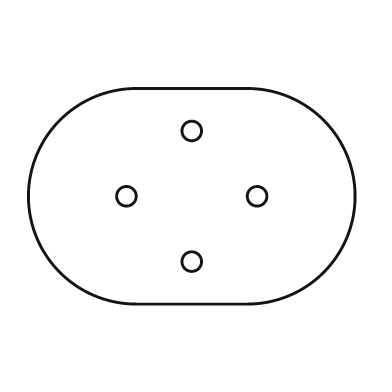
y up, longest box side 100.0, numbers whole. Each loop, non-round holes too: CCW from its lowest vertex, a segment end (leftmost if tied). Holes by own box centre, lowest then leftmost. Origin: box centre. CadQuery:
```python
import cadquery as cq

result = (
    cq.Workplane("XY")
    .moveTo(-17.0, -33.0)
    .lineTo(17.0, -33.0)
    .threePointArc((50.0, 0.0), (17.0, 33.0))
    .lineTo(-17.0, 33.0)
    .threePointArc((-50.0, 0.0), (-17.0, -33.0))
    .close()
    .moveTo(0.0, -20.0)
    .circle(3.0)
    .moveTo(-20.0, 0.0)
    .circle(3.0)
    .moveTo(20.0, 0.0)
    .circle(3.0)
    .moveTo(0.0, 20.0)
    .circle(3.0)
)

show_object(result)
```